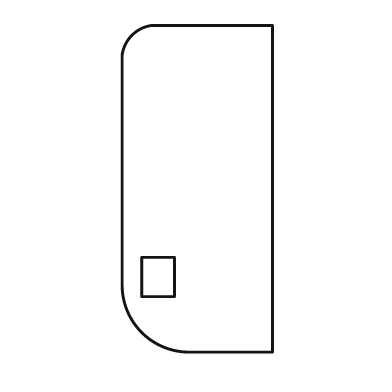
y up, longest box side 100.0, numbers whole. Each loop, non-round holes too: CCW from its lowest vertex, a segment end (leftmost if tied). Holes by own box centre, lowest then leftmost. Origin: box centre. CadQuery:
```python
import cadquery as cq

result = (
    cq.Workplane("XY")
    .moveTo(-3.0, -50.0)
    .lineTo(23.0, -50.0)
    .lineTo(23.0, 50.0)
    .lineTo(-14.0, 50.0)
    .threePointArc((-20.0, 47.0), (-23.0, 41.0))
    .lineTo(-23.0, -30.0)
    .threePointArc((-17.0, -44.0), (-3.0, -50.0))
    .close()
    .moveTo(-17.0, -33.0)
    .lineTo(-7.0, -33.0)
    .lineTo(-7.0, -21.0)
    .lineTo(-17.0, -21.0)
    .close()
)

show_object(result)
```